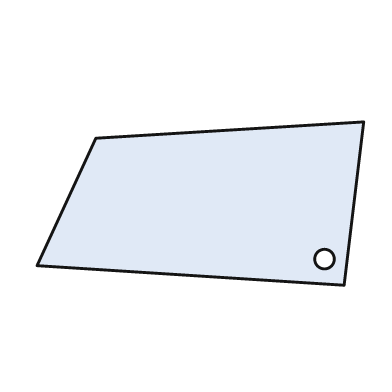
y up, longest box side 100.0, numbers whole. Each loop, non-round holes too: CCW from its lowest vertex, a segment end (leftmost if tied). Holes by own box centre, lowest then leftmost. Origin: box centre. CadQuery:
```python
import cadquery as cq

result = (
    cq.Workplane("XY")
    .moveTo(44.0, -25.0)
    .lineTo(50.0, 25.0)
    .lineTo(-32.0, 20.0)
    .lineTo(-50.0, -19.0)
    .close()
    .moveTo(38.0, -17.0)
    .circle(3.0)
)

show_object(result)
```